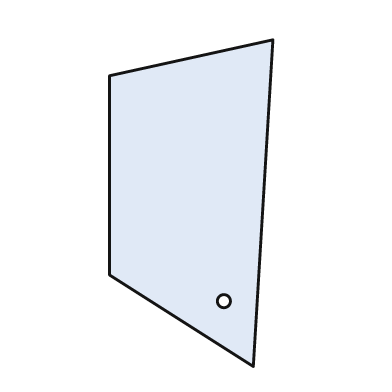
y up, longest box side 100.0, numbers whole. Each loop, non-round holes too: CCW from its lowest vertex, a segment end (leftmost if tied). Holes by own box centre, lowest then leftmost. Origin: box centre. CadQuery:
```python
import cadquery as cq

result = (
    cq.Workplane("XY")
    .moveTo(19.0, -50.0)
    .lineTo(25.0, 50.0)
    .lineTo(-25.0, 39.0)
    .lineTo(-25.0, -22.0)
    .close()
    .moveTo(10.0, -30.0)
    .circle(2.0)
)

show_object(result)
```